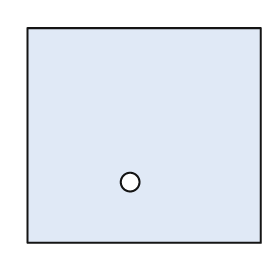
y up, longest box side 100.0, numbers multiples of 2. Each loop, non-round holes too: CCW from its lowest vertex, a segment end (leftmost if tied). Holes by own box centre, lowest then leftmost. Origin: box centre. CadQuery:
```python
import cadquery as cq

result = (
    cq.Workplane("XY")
    .moveTo(-50.0, -46.0)
    .lineTo(50.0, -46.0)
    .lineTo(50.0, 46.0)
    .lineTo(-50.0, 46.0)
    .close()
    .moveTo(-6.0, -20.0)
    .circle(4.0)
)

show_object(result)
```